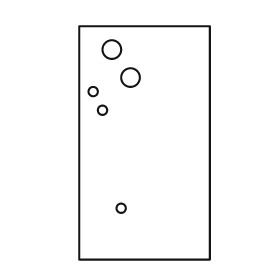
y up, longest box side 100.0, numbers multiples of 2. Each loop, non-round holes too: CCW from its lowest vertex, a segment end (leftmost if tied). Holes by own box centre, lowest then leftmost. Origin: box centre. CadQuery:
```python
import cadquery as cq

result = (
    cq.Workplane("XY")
    .moveTo(-28.0, -50.0)
    .lineTo(28.0, -50.0)
    .lineTo(28.0, 50.0)
    .lineTo(-28.0, 50.0)
    .close()
    .moveTo(-10.0, -28.0)
    .circle(2.0)
    .moveTo(-18.0, 14.0)
    .circle(2.0)
    .moveTo(-22.0, 22.0)
    .circle(2.0)
    .moveTo(-6.0, 28.0)
    .circle(4.0)
    .moveTo(-14.0, 40.0)
    .circle(4.0)
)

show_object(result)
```